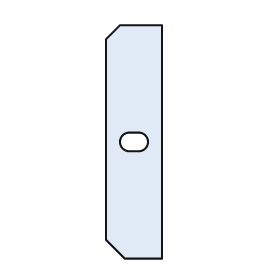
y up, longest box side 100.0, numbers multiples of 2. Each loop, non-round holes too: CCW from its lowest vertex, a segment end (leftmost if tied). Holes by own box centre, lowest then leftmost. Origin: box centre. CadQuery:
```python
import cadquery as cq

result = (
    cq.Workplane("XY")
    .moveTo(-4.0, -50.0)
    .lineTo(12.0, -50.0)
    .lineTo(12.0, 50.0)
    .lineTo(-6.0, 50.0)
    .lineTo(-12.0, 44.0)
    .lineTo(-12.0, -42.0)
    .close()
    .moveTo(-2.0, -4.0)
    .lineTo(2.0, -4.0)
    .threePointArc((6.0, 0.0), (2.0, 4.0))
    .lineTo(-2.0, 4.0)
    .threePointArc((-6.0, 0.0), (-2.0, -4.0))
    .close()
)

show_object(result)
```